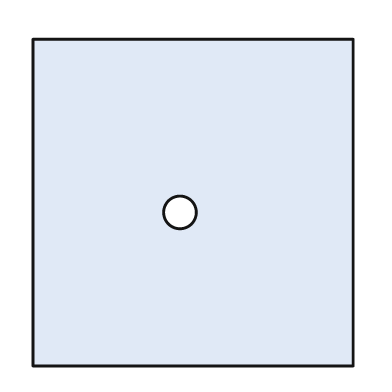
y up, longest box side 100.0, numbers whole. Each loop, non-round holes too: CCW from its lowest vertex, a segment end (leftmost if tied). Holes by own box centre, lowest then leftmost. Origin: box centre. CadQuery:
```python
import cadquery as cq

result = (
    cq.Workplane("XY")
    .moveTo(-49.0, -50.0)
    .lineTo(49.0, -50.0)
    .lineTo(49.0, 50.0)
    .lineTo(-49.0, 50.0)
    .close()
    .moveTo(-4.0, -3.0)
    .circle(5.0)
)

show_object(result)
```